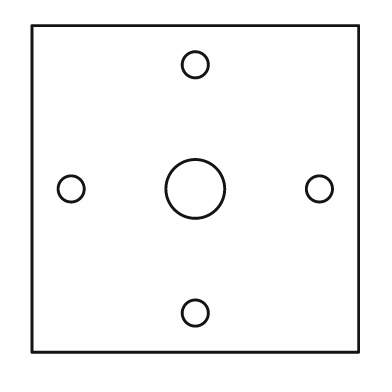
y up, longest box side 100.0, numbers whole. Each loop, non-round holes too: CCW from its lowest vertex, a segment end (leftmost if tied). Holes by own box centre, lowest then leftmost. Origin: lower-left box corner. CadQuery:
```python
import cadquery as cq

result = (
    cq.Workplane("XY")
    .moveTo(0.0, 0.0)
    .lineTo(100.0, 0.0)
    .lineTo(100.0, 100.0)
    .lineTo(0.0, 100.0)
    .close()
    .moveTo(50.0, 12.0)
    .circle(4.0)
    .moveTo(12.0, 50.0)
    .circle(4.0)
    .moveTo(50.0, 50.0)
    .circle(9.0)
    .moveTo(88.0, 50.0)
    .circle(4.0)
    .moveTo(50.0, 88.0)
    .circle(4.0)
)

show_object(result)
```